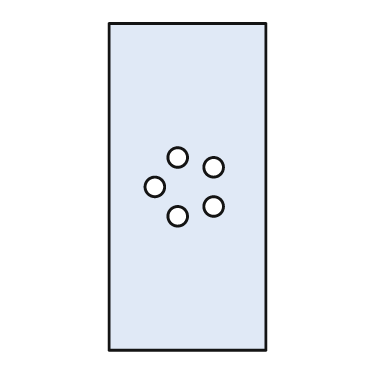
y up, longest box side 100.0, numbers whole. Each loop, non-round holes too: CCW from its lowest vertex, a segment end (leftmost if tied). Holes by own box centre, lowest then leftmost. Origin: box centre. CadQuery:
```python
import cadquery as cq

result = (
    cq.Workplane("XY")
    .moveTo(-24.0, -50.0)
    .lineTo(24.0, -50.0)
    .lineTo(24.0, 50.0)
    .lineTo(-24.0, 50.0)
    .close()
    .moveTo(-3.0, -9.0)
    .circle(3.0)
    .moveTo(8.0, -6.0)
    .circle(3.0)
    .moveTo(-10.0, 0.0)
    .circle(3.0)
    .moveTo(8.0, 6.0)
    .circle(3.0)
    .moveTo(-3.0, 9.0)
    .circle(3.0)
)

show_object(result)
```